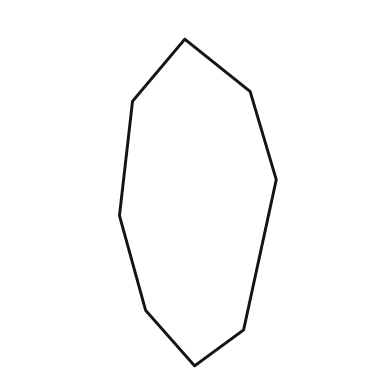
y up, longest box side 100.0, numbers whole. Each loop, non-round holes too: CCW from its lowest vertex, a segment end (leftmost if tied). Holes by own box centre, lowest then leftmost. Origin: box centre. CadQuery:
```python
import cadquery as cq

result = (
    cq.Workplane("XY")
    .moveTo(-1.0, -50.0)
    .lineTo(14.0, -39.0)
    .lineTo(24.0, 7.0)
    .lineTo(16.0, 34.0)
    .lineTo(-4.0, 50.0)
    .lineTo(-20.0, 31.0)
    .lineTo(-24.0, -4.0)
    .lineTo(-16.0, -33.0)
    .close()
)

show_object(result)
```